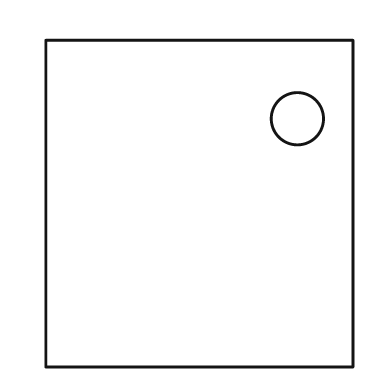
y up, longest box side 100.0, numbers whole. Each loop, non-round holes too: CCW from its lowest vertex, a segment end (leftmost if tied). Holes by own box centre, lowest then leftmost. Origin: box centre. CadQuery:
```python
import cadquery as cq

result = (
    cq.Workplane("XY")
    .moveTo(-47.0, -50.0)
    .lineTo(47.0, -50.0)
    .lineTo(47.0, 50.0)
    .lineTo(-47.0, 50.0)
    .close()
    .moveTo(30.0, 26.0)
    .circle(8.0)
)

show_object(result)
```